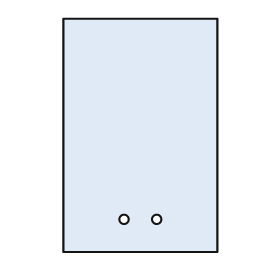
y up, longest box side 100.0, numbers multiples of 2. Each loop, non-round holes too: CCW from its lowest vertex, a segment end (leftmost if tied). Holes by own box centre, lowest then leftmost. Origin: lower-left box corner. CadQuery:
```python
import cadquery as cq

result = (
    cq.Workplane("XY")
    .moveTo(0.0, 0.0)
    .lineTo(66.0, 0.0)
    .lineTo(66.0, 100.0)
    .lineTo(0.0, 100.0)
    .close()
    .moveTo(26.0, 14.0)
    .circle(2.0)
    .moveTo(40.0, 14.0)
    .circle(2.0)
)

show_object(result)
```